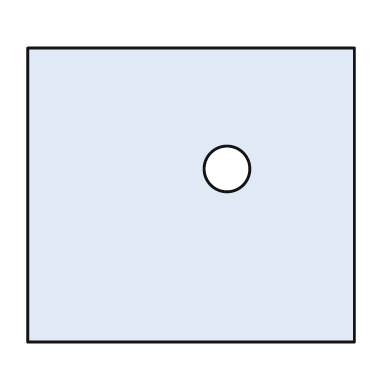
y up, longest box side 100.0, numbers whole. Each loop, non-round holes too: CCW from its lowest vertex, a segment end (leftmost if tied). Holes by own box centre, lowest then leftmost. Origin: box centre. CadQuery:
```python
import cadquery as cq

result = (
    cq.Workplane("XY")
    .moveTo(-50.0, -45.0)
    .lineTo(50.0, -45.0)
    .lineTo(50.0, 45.0)
    .lineTo(-50.0, 45.0)
    .close()
    .moveTo(11.0, 8.0)
    .circle(7.0)
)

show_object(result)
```